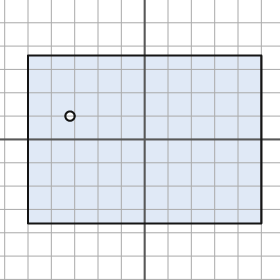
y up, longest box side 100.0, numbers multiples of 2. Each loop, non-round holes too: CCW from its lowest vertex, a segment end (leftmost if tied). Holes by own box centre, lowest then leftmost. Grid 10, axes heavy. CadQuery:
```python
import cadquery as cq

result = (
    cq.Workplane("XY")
    .moveTo(-50.0, -36.0)
    .lineTo(50.0, -36.0)
    .lineTo(50.0, 36.0)
    .lineTo(-50.0, 36.0)
    .close()
    .moveTo(-32.0, 10.0)
    .circle(2.0)
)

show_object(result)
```